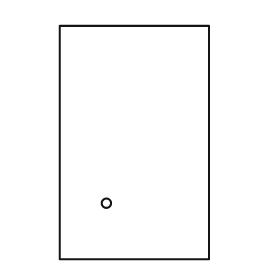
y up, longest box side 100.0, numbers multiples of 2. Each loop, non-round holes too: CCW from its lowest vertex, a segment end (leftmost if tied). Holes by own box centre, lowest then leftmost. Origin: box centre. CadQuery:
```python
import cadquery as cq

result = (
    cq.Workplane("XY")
    .moveTo(-32.0, -50.0)
    .lineTo(32.0, -50.0)
    .lineTo(32.0, 50.0)
    .lineTo(-32.0, 50.0)
    .close()
    .moveTo(-12.0, -26.0)
    .circle(2.0)
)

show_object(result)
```